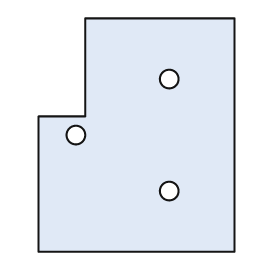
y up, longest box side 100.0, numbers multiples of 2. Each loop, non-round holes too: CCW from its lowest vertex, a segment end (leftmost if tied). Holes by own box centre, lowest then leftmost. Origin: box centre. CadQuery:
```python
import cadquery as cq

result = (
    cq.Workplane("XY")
    .moveTo(-42.0, -50.0)
    .lineTo(42.0, -50.0)
    .lineTo(42.0, 50.0)
    .lineTo(-22.0, 50.0)
    .lineTo(-22.0, 8.0)
    .lineTo(-42.0, 8.0)
    .close()
    .moveTo(14.0, -24.0)
    .circle(4.0)
    .moveTo(-26.0, 0.0)
    .circle(4.0)
    .moveTo(14.0, 24.0)
    .circle(4.0)
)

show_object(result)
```